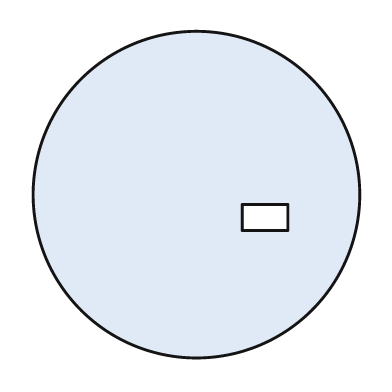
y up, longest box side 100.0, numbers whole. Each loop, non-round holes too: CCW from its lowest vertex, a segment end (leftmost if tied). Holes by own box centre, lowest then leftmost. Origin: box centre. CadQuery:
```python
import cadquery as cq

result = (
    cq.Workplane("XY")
    .moveTo(0.0, 0.0)
    .circle(50.0)
    .moveTo(14.0, -11.0)
    .lineTo(28.0, -11.0)
    .lineTo(28.0, -3.0)
    .lineTo(14.0, -3.0)
    .close()
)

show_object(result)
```